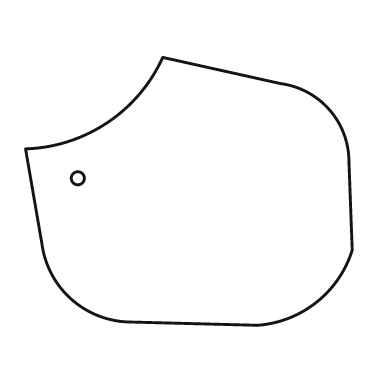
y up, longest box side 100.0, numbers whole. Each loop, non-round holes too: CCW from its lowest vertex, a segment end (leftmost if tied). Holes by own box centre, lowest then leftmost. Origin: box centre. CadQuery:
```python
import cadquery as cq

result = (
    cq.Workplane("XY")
    .moveTo(21.0, -41.0)
    .threePointArc((39.0, -34.0), (50.0, -18.0))
    .lineTo(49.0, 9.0)
    .threePointArc((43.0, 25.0), (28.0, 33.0))
    .lineTo(-8.0, 41.0)
    .threePointArc((-25.0, 21.0), (-50.0, 13.0))
    .lineTo(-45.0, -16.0)
    .threePointArc((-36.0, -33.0), (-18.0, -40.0))
    .close()
    .moveTo(-34.0, 4.0)
    .circle(2.0)
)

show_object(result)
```